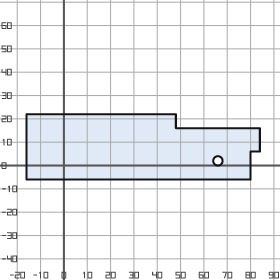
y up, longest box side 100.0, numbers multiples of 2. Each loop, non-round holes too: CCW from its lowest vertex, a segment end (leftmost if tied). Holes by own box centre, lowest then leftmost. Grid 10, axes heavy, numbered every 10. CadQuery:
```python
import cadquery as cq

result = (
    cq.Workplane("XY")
    .moveTo(-16.0, -6.0)
    .lineTo(80.0, -6.0)
    .lineTo(80.0, 6.0)
    .lineTo(84.0, 6.0)
    .lineTo(84.0, 16.0)
    .lineTo(48.0, 16.0)
    .lineTo(48.0, 22.0)
    .lineTo(-16.0, 22.0)
    .close()
    .moveTo(66.0, 2.0)
    .circle(2.0)
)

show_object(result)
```